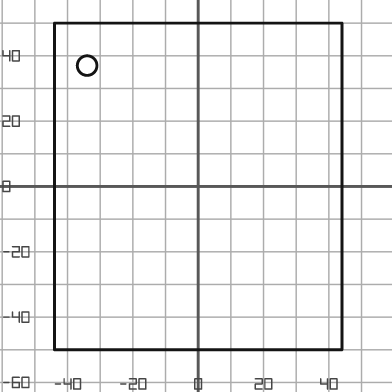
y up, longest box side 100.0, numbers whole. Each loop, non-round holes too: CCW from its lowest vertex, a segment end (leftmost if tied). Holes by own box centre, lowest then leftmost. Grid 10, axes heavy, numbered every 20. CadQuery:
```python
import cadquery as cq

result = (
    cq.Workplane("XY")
    .moveTo(-44.0, -50.0)
    .lineTo(44.0, -50.0)
    .lineTo(44.0, 50.0)
    .lineTo(-44.0, 50.0)
    .close()
    .moveTo(-34.0, 37.0)
    .circle(3.0)
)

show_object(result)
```